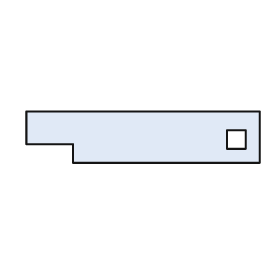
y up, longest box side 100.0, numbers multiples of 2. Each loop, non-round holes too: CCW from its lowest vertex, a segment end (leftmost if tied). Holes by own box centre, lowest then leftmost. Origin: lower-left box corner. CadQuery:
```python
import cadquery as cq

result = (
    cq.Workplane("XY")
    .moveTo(20.0, 0.0)
    .lineTo(100.0, 0.0)
    .lineTo(100.0, 22.0)
    .lineTo(0.0, 22.0)
    .lineTo(0.0, 8.0)
    .lineTo(20.0, 8.0)
    .close()
    .moveTo(86.0, 6.0)
    .lineTo(94.0, 6.0)
    .lineTo(94.0, 14.0)
    .lineTo(86.0, 14.0)
    .close()
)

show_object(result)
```